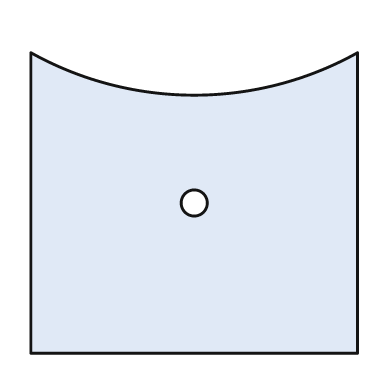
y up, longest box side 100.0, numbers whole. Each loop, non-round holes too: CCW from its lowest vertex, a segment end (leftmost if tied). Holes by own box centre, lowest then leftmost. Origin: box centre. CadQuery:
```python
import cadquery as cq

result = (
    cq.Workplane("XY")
    .moveTo(-50.0, -46.0)
    .lineTo(50.0, -46.0)
    .lineTo(50.0, 46.0)
    .threePointArc((0.0, 33.0), (-50.0, 46.0))
    .close()
    .moveTo(0.0, 0.0)
    .circle(4.0)
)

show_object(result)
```